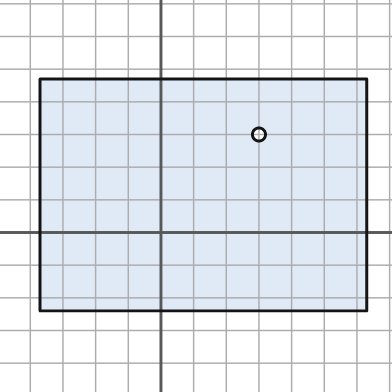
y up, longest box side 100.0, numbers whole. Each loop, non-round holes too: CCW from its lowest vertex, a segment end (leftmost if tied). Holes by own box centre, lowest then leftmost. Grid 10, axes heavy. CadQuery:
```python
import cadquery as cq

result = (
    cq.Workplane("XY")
    .moveTo(-37.0, -24.0)
    .lineTo(63.0, -24.0)
    .lineTo(63.0, 47.0)
    .lineTo(-37.0, 47.0)
    .close()
    .moveTo(30.0, 30.0)
    .circle(2.0)
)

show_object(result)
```